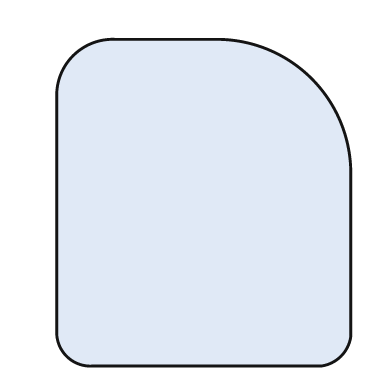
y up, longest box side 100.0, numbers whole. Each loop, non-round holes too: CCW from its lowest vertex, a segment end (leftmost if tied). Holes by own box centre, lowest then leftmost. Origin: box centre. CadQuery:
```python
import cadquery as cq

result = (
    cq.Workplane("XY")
    .moveTo(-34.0, -50.0)
    .lineTo(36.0, -50.0)
    .threePointArc((42.0, -47.0), (45.0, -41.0))
    .lineTo(45.0, 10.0)
    .threePointArc((33.0, 38.0), (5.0, 50.0))
    .lineTo(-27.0, 50.0)
    .threePointArc((-40.0, 45.0), (-45.0, 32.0))
    .lineTo(-45.0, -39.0)
    .threePointArc((-42.0, -47.0), (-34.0, -50.0))
    .close()
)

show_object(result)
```